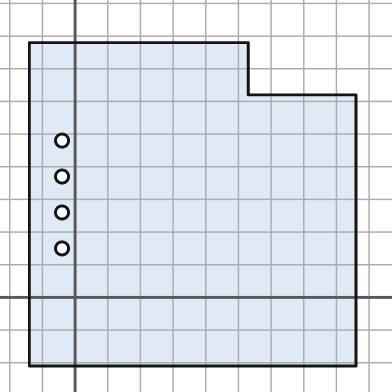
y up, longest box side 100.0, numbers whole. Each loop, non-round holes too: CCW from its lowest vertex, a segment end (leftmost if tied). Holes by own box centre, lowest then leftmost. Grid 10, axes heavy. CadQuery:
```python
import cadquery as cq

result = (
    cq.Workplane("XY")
    .moveTo(-14.0, -21.0)
    .lineTo(86.0, -21.0)
    .lineTo(86.0, 62.0)
    .lineTo(53.0, 62.0)
    .lineTo(53.0, 78.0)
    .lineTo(-14.0, 78.0)
    .close()
    .moveTo(-4.0, 15.0)
    .circle(2.0)
    .moveTo(-4.0, 26.0)
    .circle(2.0)
    .moveTo(-4.0, 37.0)
    .circle(2.0)
    .moveTo(-4.0, 48.0)
    .circle(2.0)
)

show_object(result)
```